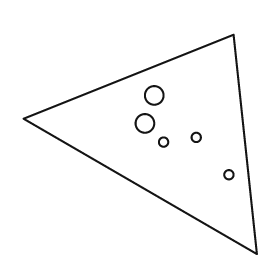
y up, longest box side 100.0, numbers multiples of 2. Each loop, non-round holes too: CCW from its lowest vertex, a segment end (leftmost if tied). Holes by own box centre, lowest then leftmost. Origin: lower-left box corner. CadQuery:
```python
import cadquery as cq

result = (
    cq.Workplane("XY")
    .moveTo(100.0, 0.0)
    .lineTo(90.0, 94.0)
    .lineTo(0.0, 58.0)
    .close()
    .moveTo(88.0, 34.0)
    .circle(2.0)
    .moveTo(60.0, 48.0)
    .circle(2.0)
    .moveTo(74.0, 50.0)
    .circle(2.0)
    .moveTo(52.0, 56.0)
    .circle(4.0)
    .moveTo(56.0, 68.0)
    .circle(4.0)
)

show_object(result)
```